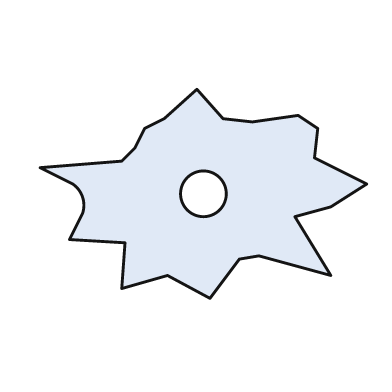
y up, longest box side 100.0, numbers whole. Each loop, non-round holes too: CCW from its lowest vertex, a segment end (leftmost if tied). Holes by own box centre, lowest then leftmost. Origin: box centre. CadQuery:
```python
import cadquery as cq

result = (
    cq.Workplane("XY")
    .moveTo(2.0, -32.0)
    .lineTo(11.0, -20.0)
    .lineTo(17.0, -19.0)
    .lineTo(39.0, -25.0)
    .lineTo(28.0, -7.0)
    .lineTo(39.0, -4.0)
    .lineTo(50.0, 3.0)
    .lineTo(34.0, 11.0)
    .lineTo(35.0, 20.0)
    .lineTo(29.0, 24.0)
    .lineTo(15.0, 22.0)
    .lineTo(6.0, 23.0)
    .lineTo(-2.0, 32.0)
    .lineTo(-12.0, 23.0)
    .lineTo(-18.0, 20.0)
    .lineTo(-21.0, 14.0)
    .lineTo(-25.0, 10.0)
    .lineTo(-50.0, 8.0)
    .lineTo(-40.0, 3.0)
    .threePointArc((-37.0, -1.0), (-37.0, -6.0))
    .lineTo(-41.0, -14.0)
    .lineTo(-24.0, -15.0)
    .lineTo(-25.0, -29.0)
    .lineTo(-11.0, -25.0)
    .close()
    .moveTo(0.0, 0.0)
    .circle(7.0)
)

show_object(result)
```